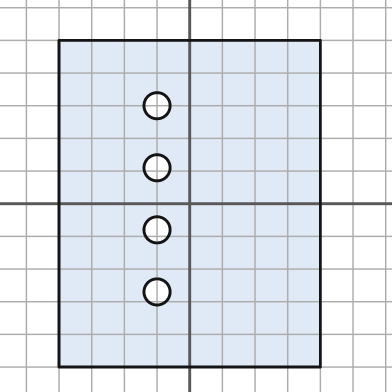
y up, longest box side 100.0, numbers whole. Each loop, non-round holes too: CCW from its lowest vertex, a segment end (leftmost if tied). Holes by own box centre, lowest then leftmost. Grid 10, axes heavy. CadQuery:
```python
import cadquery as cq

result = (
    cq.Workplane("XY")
    .moveTo(-40.0, -50.0)
    .lineTo(40.0, -50.0)
    .lineTo(40.0, 50.0)
    .lineTo(-40.0, 50.0)
    .close()
    .moveTo(-10.0, -27.0)
    .circle(4.0)
    .moveTo(-10.0, -8.0)
    .circle(4.0)
    .moveTo(-10.0, 11.0)
    .circle(4.0)
    .moveTo(-10.0, 30.0)
    .circle(4.0)
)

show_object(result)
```